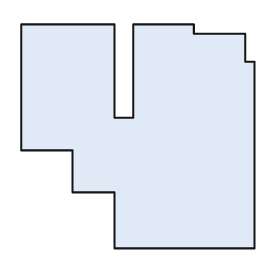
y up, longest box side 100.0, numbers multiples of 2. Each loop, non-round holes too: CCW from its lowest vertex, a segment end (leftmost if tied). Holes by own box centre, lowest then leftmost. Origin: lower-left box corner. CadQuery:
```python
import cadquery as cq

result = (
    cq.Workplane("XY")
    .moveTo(40.0, 0.0)
    .lineTo(100.0, 0.0)
    .lineTo(100.0, 80.0)
    .lineTo(96.0, 80.0)
    .lineTo(96.0, 92.0)
    .lineTo(74.0, 92.0)
    .lineTo(74.0, 96.0)
    .lineTo(48.0, 96.0)
    .lineTo(48.0, 56.0)
    .lineTo(40.0, 56.0)
    .lineTo(40.0, 96.0)
    .lineTo(0.0, 96.0)
    .lineTo(0.0, 42.0)
    .lineTo(22.0, 42.0)
    .lineTo(22.0, 24.0)
    .lineTo(40.0, 24.0)
    .close()
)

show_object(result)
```